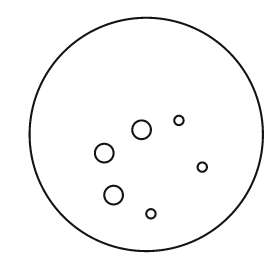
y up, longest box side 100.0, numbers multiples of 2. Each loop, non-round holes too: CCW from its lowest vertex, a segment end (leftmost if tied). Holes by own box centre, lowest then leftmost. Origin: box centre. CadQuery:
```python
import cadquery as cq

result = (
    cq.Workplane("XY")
    .moveTo(0.0, 0.0)
    .circle(50.0)
    .moveTo(2.0, -34.0)
    .circle(2.0)
    .moveTo(-14.0, -26.0)
    .circle(4.0)
    .moveTo(24.0, -14.0)
    .circle(2.0)
    .moveTo(-18.0, -8.0)
    .circle(4.0)
    .moveTo(-2.0, 2.0)
    .circle(4.0)
    .moveTo(14.0, 6.0)
    .circle(2.0)
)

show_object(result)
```